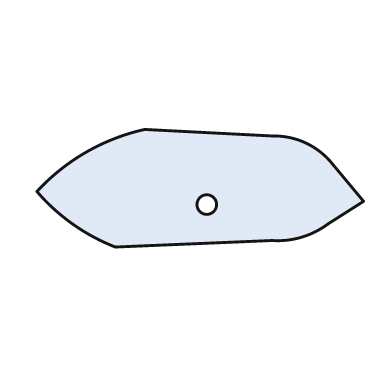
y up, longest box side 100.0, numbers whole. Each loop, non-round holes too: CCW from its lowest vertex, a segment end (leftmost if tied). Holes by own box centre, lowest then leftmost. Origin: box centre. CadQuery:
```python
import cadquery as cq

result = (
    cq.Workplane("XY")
    .moveTo(-26.0, -18.0)
    .lineTo(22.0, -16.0)
    .threePointArc((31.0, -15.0), (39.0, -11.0))
    .lineTo(50.0, -4.0)
    .lineTo(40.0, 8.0)
    .threePointArc((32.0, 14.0), (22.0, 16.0))
    .lineTo(-17.0, 18.0)
    .threePointArc((-35.0, 11.0), (-50.0, -1.0))
    .threePointArc((-39.0, -11.0), (-26.0, -18.0))
    .close()
    .moveTo(2.0, -5.0)
    .circle(3.0)
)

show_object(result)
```